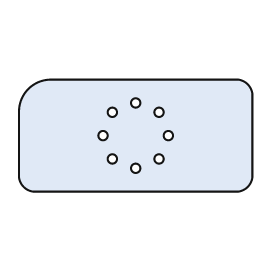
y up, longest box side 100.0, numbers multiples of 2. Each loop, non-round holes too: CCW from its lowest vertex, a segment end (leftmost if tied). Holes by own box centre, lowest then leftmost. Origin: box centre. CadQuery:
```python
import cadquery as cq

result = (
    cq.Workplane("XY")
    .moveTo(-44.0, -24.0)
    .lineTo(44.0, -24.0)
    .threePointArc((48.0, -22.0), (50.0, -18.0))
    .lineTo(50.0, 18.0)
    .threePointArc((48.0, 22.0), (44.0, 24.0))
    .lineTo(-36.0, 24.0)
    .threePointArc((-46.0, 20.0), (-50.0, 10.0))
    .lineTo(-50.0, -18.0)
    .threePointArc((-48.0, -22.0), (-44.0, -24.0))
    .close()
    .moveTo(0.0, -14.0)
    .circle(2.0)
    .moveTo(-10.0, -10.0)
    .circle(2.0)
    .moveTo(10.0, -10.0)
    .circle(2.0)
    .moveTo(-14.0, 0.0)
    .circle(2.0)
    .moveTo(14.0, 0.0)
    .circle(2.0)
    .moveTo(-10.0, 10.0)
    .circle(2.0)
    .moveTo(10.0, 10.0)
    .circle(2.0)
    .moveTo(0.0, 14.0)
    .circle(2.0)
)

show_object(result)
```